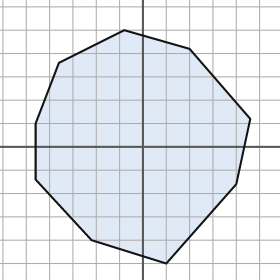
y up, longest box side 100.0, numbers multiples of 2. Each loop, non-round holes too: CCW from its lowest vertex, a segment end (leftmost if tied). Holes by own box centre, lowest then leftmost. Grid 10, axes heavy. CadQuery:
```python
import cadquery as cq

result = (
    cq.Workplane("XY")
    .moveTo(10.0, -50.0)
    .lineTo(40.0, -16.0)
    .lineTo(46.0, 12.0)
    .lineTo(20.0, 42.0)
    .lineTo(-8.0, 50.0)
    .lineTo(-36.0, 36.0)
    .lineTo(-46.0, 10.0)
    .lineTo(-46.0, -14.0)
    .lineTo(-22.0, -40.0)
    .close()
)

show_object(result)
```